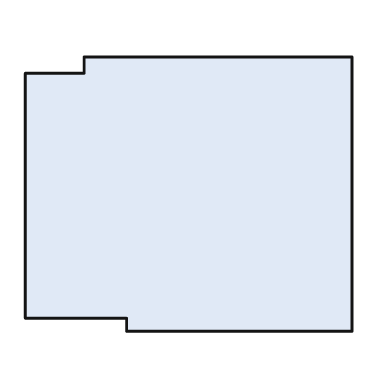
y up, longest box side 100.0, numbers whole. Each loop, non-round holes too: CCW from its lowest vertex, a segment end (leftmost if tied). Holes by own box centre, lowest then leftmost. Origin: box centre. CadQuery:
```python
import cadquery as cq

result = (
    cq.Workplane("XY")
    .moveTo(-19.0, -42.0)
    .lineTo(50.0, -42.0)
    .lineTo(50.0, 42.0)
    .lineTo(-32.0, 42.0)
    .lineTo(-32.0, 37.0)
    .lineTo(-50.0, 37.0)
    .lineTo(-50.0, -38.0)
    .lineTo(-19.0, -38.0)
    .close()
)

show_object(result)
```